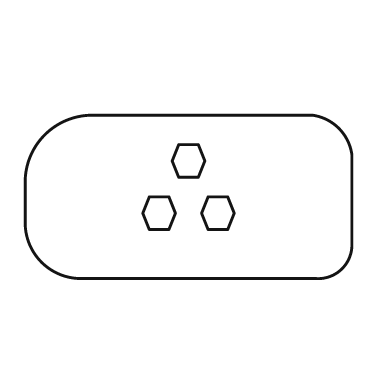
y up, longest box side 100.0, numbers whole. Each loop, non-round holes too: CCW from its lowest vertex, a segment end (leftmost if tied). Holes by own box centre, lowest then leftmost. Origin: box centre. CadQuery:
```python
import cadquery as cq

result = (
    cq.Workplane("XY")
    .moveTo(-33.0, -25.0)
    .lineTo(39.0, -25.0)
    .threePointArc((47.0, -22.0), (50.0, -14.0))
    .lineTo(50.0, 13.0)
    .threePointArc((46.0, 21.0), (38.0, 25.0))
    .lineTo(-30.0, 25.0)
    .threePointArc((-44.0, 19.0), (-50.0, 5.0))
    .lineTo(-50.0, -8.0)
    .threePointArc((-45.0, -20.0), (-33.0, -25.0))
    .close()
    .moveTo(-12.0, -10.0)
    .lineTo(-6.0, -10.0)
    .lineTo(-4.0, -5.0)
    .lineTo(-6.0, 0.0)
    .lineTo(-12.0, 0.0)
    .lineTo(-14.0, -5.0)
    .close()
    .moveTo(6.0, -10.0)
    .lineTo(12.0, -10.0)
    .lineTo(14.0, -5.0)
    .lineTo(12.0, 0.0)
    .lineTo(6.0, 0.0)
    .lineTo(4.0, -5.0)
    .close()
    .moveTo(-3.0, 6.0)
    .lineTo(3.0, 6.0)
    .lineTo(5.0, 11.0)
    .lineTo(3.0, 16.0)
    .lineTo(-3.0, 16.0)
    .lineTo(-5.0, 11.0)
    .close()
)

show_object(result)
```